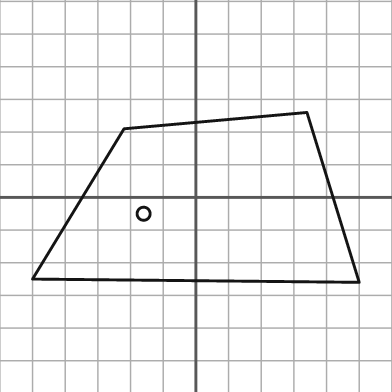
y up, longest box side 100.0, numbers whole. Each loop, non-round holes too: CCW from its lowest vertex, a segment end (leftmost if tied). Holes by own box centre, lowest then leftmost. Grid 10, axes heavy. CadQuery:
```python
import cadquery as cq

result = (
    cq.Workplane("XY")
    .moveTo(50.0, -26.0)
    .lineTo(34.0, 26.0)
    .lineTo(-22.0, 21.0)
    .lineTo(-50.0, -25.0)
    .close()
    .moveTo(-16.0, -5.0)
    .circle(2.0)
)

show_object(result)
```